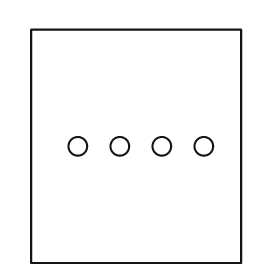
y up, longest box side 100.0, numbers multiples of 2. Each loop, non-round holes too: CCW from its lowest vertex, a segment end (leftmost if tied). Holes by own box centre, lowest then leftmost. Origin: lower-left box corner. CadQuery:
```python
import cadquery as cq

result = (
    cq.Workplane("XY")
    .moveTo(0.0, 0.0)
    .lineTo(90.0, 0.0)
    .lineTo(90.0, 100.0)
    .lineTo(0.0, 100.0)
    .close()
    .moveTo(20.0, 50.0)
    .circle(4.0)
    .moveTo(38.0, 50.0)
    .circle(4.0)
    .moveTo(56.0, 50.0)
    .circle(4.0)
    .moveTo(74.0, 50.0)
    .circle(4.0)
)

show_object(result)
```